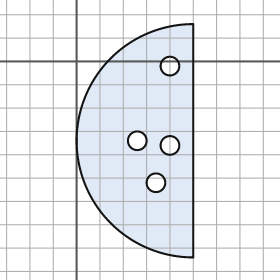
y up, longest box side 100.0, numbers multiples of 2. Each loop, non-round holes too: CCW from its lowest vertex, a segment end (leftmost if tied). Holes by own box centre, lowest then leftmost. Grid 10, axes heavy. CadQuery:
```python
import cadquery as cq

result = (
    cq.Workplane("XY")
    .moveTo(50.0, -84.0)
    .lineTo(50.0, 16.0)
    .threePointArc((0.0, -34.0), (50.0, -84.0))
    .close()
    .moveTo(34.0, -52.0)
    .circle(4.0)
    .moveTo(40.0, -36.0)
    .circle(4.0)
    .moveTo(26.0, -34.0)
    .circle(4.0)
    .moveTo(40.0, -2.0)
    .circle(4.0)
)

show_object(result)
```